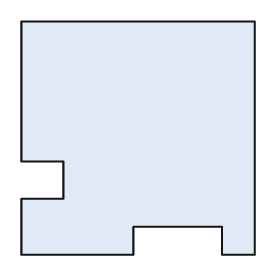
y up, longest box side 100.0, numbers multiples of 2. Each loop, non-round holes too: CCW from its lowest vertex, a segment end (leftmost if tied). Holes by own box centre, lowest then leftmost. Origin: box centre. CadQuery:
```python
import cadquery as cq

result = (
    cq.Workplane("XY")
    .moveTo(-50.0, -50.0)
    .lineTo(-2.0, -50.0)
    .lineTo(-2.0, -38.0)
    .lineTo(36.0, -38.0)
    .lineTo(36.0, -50.0)
    .lineTo(50.0, -50.0)
    .lineTo(50.0, 50.0)
    .lineTo(-50.0, 50.0)
    .lineTo(-50.0, -10.0)
    .lineTo(-32.0, -10.0)
    .lineTo(-32.0, -26.0)
    .lineTo(-50.0, -26.0)
    .close()
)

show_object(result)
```